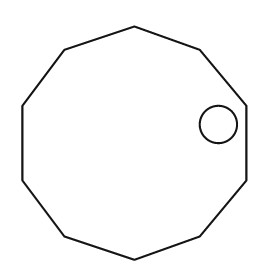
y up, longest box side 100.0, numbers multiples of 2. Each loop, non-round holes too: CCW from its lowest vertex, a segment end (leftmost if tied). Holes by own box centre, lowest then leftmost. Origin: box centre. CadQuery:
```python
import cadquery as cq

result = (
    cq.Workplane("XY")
    .moveTo(0.0, -50.0)
    .lineTo(28.0, -40.0)
    .lineTo(48.0, -16.0)
    .lineTo(48.0, 16.0)
    .lineTo(28.0, 40.0)
    .lineTo(0.0, 50.0)
    .lineTo(-30.0, 40.0)
    .lineTo(-48.0, 16.0)
    .lineTo(-48.0, -16.0)
    .lineTo(-30.0, -40.0)
    .close()
    .moveTo(36.0, 8.0)
    .circle(8.0)
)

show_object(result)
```